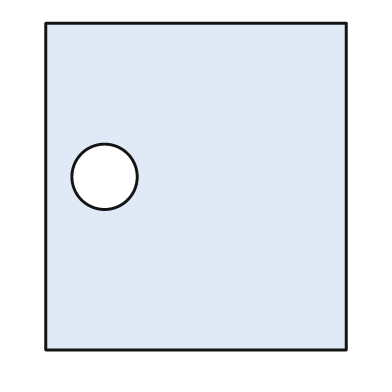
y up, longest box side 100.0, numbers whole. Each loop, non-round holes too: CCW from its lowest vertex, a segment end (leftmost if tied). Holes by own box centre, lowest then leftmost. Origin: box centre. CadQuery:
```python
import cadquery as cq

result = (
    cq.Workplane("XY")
    .moveTo(-46.0, -50.0)
    .lineTo(46.0, -50.0)
    .lineTo(46.0, 50.0)
    .lineTo(-46.0, 50.0)
    .close()
    .moveTo(-28.0, 3.0)
    .circle(10.0)
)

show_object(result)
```